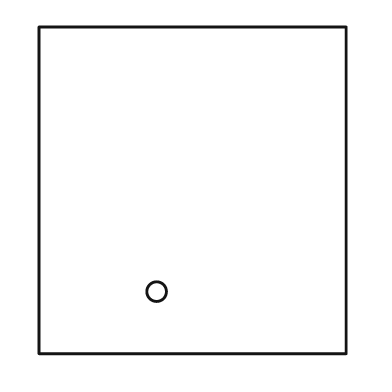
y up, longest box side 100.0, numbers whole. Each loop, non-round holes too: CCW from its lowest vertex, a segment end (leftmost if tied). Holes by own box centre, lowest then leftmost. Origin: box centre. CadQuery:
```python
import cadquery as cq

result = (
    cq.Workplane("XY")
    .moveTo(-47.0, -50.0)
    .lineTo(47.0, -50.0)
    .lineTo(47.0, 50.0)
    .lineTo(-47.0, 50.0)
    .close()
    .moveTo(-11.0, -31.0)
    .circle(3.0)
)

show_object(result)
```